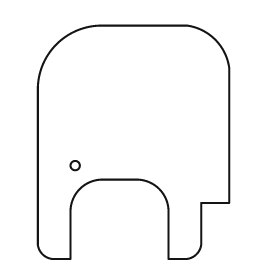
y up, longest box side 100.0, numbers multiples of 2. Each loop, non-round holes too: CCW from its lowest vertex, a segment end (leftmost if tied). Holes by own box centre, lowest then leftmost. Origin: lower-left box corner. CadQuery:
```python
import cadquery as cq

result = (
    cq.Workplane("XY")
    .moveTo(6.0, 0.0)
    .lineTo(14.0, 0.0)
    .lineTo(14.0, 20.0)
    .threePointArc((18.0, 30.0), (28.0, 34.0))
    .lineTo(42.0, 34.0)
    .threePointArc((52.0, 30.0), (56.0, 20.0))
    .lineTo(56.0, 0.0)
    .lineTo(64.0, 0.0)
    .threePointArc((68.0, 2.0), (70.0, 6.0))
    .lineTo(70.0, 24.0)
    .lineTo(82.0, 24.0)
    .lineTo(82.0, 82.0)
    .threePointArc((76.0, 94.0), (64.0, 100.0))
    .lineTo(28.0, 100.0)
    .threePointArc((8.0, 92.0), (0.0, 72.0))
    .lineTo(0.0, 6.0)
    .threePointArc((2.0, 2.0), (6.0, 0.0))
    .close()
    .moveTo(16.0, 40.0)
    .circle(2.0)
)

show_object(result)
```